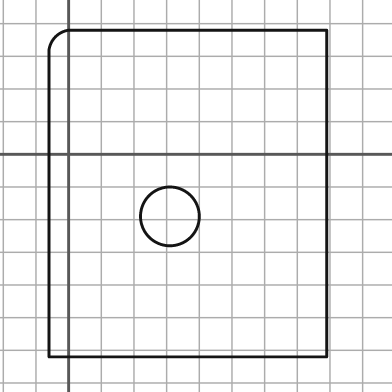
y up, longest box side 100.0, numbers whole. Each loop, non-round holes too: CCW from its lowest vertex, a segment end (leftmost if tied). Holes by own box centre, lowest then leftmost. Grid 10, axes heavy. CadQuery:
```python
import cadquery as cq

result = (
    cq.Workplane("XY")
    .moveTo(-6.0, -62.0)
    .lineTo(79.0, -62.0)
    .lineTo(79.0, 38.0)
    .lineTo(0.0, 38.0)
    .threePointArc((-4.0, 36.0), (-6.0, 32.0))
    .close()
    .moveTo(31.0, -19.0)
    .circle(9.0)
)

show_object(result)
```